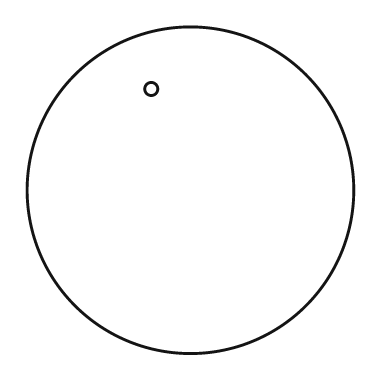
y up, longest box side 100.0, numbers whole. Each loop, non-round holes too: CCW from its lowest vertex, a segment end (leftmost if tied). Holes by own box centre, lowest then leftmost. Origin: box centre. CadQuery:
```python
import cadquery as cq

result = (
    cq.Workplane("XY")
    .moveTo(0.0, 0.0)
    .circle(50.0)
    .moveTo(-12.0, 31.0)
    .circle(2.0)
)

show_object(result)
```